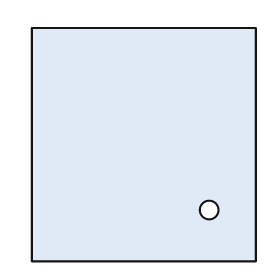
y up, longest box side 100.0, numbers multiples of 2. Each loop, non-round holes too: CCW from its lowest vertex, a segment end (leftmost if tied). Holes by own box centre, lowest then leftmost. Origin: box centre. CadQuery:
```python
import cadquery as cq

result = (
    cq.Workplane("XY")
    .moveTo(-48.0, -50.0)
    .lineTo(48.0, -50.0)
    .lineTo(48.0, 50.0)
    .lineTo(-48.0, 50.0)
    .close()
    .moveTo(28.0, -28.0)
    .circle(4.0)
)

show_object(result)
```